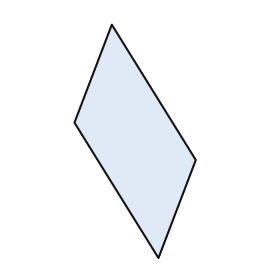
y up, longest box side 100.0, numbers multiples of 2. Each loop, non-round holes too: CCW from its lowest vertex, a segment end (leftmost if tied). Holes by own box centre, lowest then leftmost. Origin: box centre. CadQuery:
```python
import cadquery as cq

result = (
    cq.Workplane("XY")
    .moveTo(10.0, -50.0)
    .lineTo(26.0, -8.0)
    .lineTo(-10.0, 50.0)
    .lineTo(-26.0, 8.0)
    .close()
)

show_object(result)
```